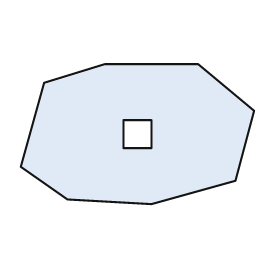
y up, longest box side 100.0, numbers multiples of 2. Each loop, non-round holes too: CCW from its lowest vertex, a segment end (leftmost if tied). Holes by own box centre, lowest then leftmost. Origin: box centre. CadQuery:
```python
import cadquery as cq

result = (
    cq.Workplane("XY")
    .moveTo(6.0, -30.0)
    .lineTo(42.0, -20.0)
    .lineTo(50.0, 10.0)
    .lineTo(26.0, 30.0)
    .lineTo(-14.0, 30.0)
    .lineTo(-40.0, 22.0)
    .lineTo(-50.0, -14.0)
    .lineTo(-30.0, -28.0)
    .close()
    .moveTo(-6.0, -6.0)
    .lineTo(6.0, -6.0)
    .lineTo(6.0, 6.0)
    .lineTo(-6.0, 6.0)
    .close()
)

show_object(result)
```